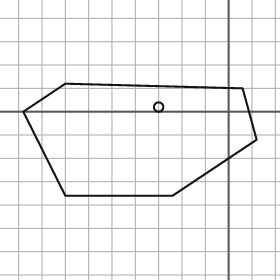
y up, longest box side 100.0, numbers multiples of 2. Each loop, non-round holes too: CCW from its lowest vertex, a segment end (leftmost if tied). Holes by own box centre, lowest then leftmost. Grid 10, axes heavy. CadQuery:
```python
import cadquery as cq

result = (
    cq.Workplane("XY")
    .moveTo(-70.0, -36.0)
    .lineTo(-24.0, -36.0)
    .lineTo(12.0, -12.0)
    .lineTo(6.0, 10.0)
    .lineTo(-70.0, 12.0)
    .lineTo(-88.0, 0.0)
    .close()
    .moveTo(-30.0, 2.0)
    .circle(2.0)
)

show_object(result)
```